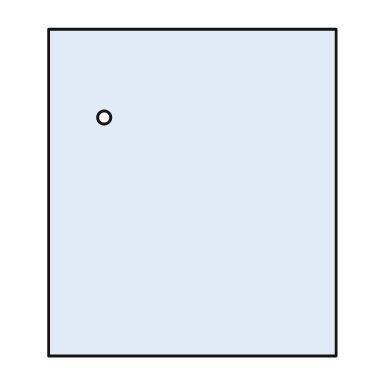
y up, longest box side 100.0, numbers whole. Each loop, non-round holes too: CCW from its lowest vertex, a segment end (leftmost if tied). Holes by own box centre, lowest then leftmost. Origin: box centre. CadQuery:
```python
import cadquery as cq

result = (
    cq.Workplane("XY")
    .moveTo(-44.0, -50.0)
    .lineTo(44.0, -50.0)
    .lineTo(44.0, 50.0)
    .lineTo(-44.0, 50.0)
    .close()
    .moveTo(-27.0, 23.0)
    .circle(2.0)
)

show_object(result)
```